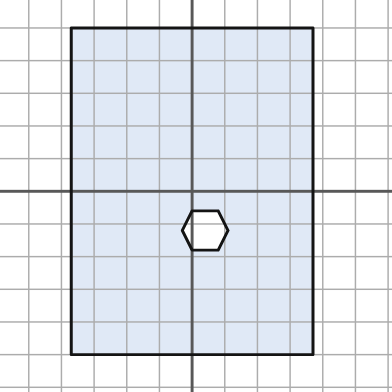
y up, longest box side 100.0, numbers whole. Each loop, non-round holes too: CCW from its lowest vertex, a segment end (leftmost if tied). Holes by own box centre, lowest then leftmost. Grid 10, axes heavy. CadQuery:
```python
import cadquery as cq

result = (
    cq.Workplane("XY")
    .moveTo(-37.0, -50.0)
    .lineTo(37.0, -50.0)
    .lineTo(37.0, 50.0)
    .lineTo(-37.0, 50.0)
    .close()
    .moveTo(0.0, -18.0)
    .lineTo(8.0, -18.0)
    .lineTo(11.0, -12.0)
    .lineTo(8.0, -6.0)
    .lineTo(0.0, -6.0)
    .lineTo(-3.0, -12.0)
    .close()
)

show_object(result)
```